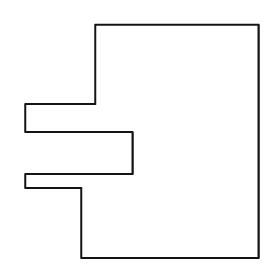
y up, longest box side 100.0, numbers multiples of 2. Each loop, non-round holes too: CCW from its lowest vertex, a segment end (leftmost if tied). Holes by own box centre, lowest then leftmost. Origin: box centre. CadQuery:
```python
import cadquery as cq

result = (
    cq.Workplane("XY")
    .moveTo(-26.0, -50.0)
    .lineTo(50.0, -50.0)
    .lineTo(50.0, 50.0)
    .lineTo(-20.0, 50.0)
    .lineTo(-20.0, 16.0)
    .lineTo(-50.0, 16.0)
    .lineTo(-50.0, 4.0)
    .lineTo(-4.0, 4.0)
    .lineTo(-4.0, -14.0)
    .lineTo(-50.0, -14.0)
    .lineTo(-50.0, -20.0)
    .lineTo(-26.0, -20.0)
    .close()
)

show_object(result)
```